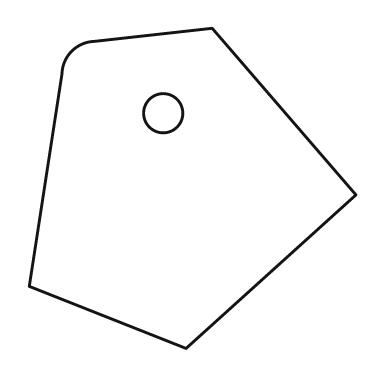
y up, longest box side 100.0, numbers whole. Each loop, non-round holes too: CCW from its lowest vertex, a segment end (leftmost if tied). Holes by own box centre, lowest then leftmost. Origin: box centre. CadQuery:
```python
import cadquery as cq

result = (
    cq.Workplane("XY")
    .moveTo(-2.0, -49.0)
    .lineTo(50.0, -2.0)
    .lineTo(6.0, 49.0)
    .lineTo(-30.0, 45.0)
    .threePointArc((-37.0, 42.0), (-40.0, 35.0))
    .lineTo(-50.0, -30.0)
    .close()
    .moveTo(-9.0, 23.0)
    .circle(6.0)
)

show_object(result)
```